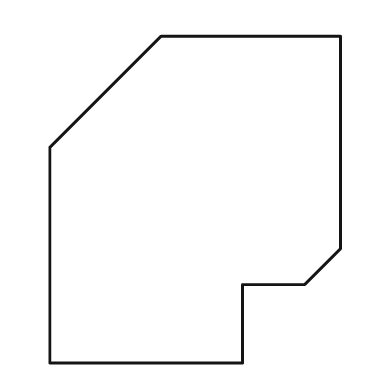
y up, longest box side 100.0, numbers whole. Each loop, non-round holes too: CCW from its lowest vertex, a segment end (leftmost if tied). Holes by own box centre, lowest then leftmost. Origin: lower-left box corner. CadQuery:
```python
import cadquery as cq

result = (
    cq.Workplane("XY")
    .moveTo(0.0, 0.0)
    .lineTo(59.0, 0.0)
    .lineTo(59.0, 24.0)
    .lineTo(78.0, 24.0)
    .lineTo(89.0, 35.0)
    .lineTo(89.0, 100.0)
    .lineTo(34.0, 100.0)
    .lineTo(0.0, 66.0)
    .close()
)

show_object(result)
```